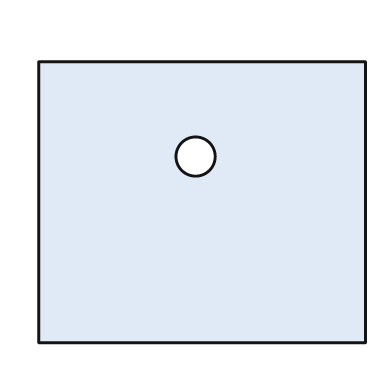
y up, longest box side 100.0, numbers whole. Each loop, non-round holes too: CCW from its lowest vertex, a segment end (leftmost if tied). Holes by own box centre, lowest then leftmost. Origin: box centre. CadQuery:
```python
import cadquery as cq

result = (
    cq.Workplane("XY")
    .moveTo(-50.0, -43.0)
    .lineTo(50.0, -43.0)
    .lineTo(50.0, 43.0)
    .lineTo(-50.0, 43.0)
    .close()
    .moveTo(-2.0, 14.0)
    .circle(6.0)
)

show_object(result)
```